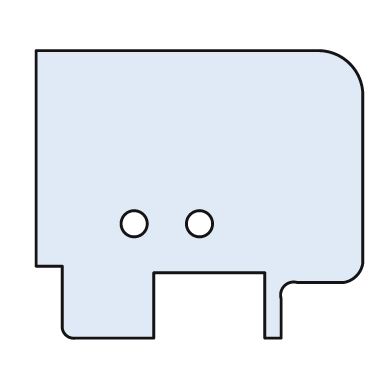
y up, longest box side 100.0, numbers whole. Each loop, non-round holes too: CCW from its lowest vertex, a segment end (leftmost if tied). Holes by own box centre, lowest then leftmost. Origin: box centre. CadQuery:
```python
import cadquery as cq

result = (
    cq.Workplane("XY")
    .moveTo(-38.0, -44.0)
    .lineTo(-14.0, -44.0)
    .lineTo(-14.0, -24.0)
    .lineTo(20.0, -24.0)
    .lineTo(20.0, -44.0)
    .lineTo(25.0, -44.0)
    .lineTo(25.0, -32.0)
    .threePointArc((26.0, -28.0), (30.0, -27.0))
    .lineTo(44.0, -27.0)
    .threePointArc((48.0, -25.0), (50.0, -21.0))
    .lineTo(50.0, 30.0)
    .threePointArc((46.0, 40.0), (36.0, 44.0))
    .lineTo(-50.0, 44.0)
    .lineTo(-50.0, -22.0)
    .lineTo(-42.0, -22.0)
    .lineTo(-42.0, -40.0)
    .threePointArc((-41.0, -43.0), (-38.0, -44.0))
    .close()
    .moveTo(-20.0, -9.0)
    .circle(4.0)
    .moveTo(0.0, -9.0)
    .circle(4.0)
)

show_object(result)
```